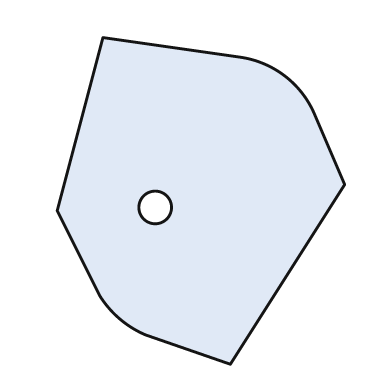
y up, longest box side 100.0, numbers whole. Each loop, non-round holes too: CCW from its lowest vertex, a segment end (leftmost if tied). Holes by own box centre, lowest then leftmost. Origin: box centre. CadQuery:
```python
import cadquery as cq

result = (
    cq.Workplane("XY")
    .moveTo(9.0, -50.0)
    .lineTo(44.0, 5.0)
    .lineTo(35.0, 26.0)
    .threePointArc((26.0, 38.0), (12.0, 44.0))
    .lineTo(-30.0, 50.0)
    .lineTo(-44.0, -3.0)
    .lineTo(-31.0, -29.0)
    .threePointArc((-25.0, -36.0), (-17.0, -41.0))
    .close()
    .moveTo(-14.0, -2.0)
    .circle(5.0)
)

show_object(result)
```